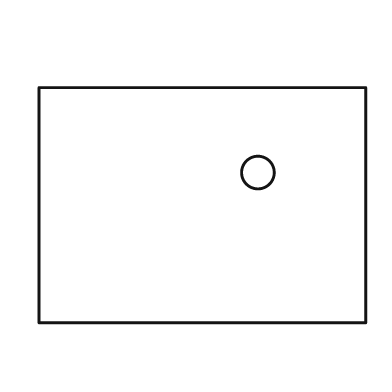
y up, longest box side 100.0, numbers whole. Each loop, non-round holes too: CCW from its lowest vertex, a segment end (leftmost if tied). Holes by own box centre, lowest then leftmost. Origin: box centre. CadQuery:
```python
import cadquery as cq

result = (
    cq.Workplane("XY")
    .moveTo(-50.0, -36.0)
    .lineTo(50.0, -36.0)
    .lineTo(50.0, 36.0)
    .lineTo(-50.0, 36.0)
    .close()
    .moveTo(17.0, 10.0)
    .circle(5.0)
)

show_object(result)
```